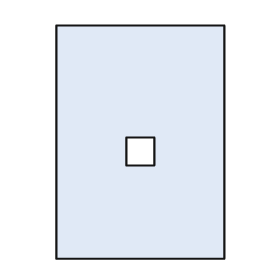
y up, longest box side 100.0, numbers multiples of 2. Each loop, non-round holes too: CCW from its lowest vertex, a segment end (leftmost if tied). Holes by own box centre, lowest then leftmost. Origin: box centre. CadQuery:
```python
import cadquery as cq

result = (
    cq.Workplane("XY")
    .moveTo(-36.0, -50.0)
    .lineTo(36.0, -50.0)
    .lineTo(36.0, 50.0)
    .lineTo(-36.0, 50.0)
    .close()
    .moveTo(-6.0, -10.0)
    .lineTo(6.0, -10.0)
    .lineTo(6.0, 2.0)
    .lineTo(-6.0, 2.0)
    .close()
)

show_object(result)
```